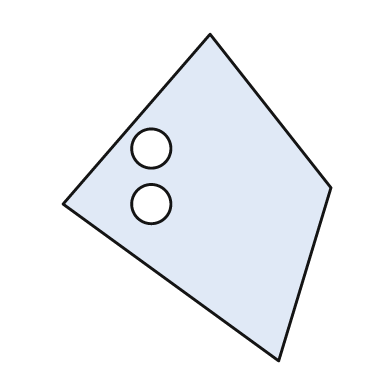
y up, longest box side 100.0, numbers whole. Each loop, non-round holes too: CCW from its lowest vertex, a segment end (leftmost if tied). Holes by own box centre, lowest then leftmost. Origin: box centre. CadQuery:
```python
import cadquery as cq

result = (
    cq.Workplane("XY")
    .moveTo(25.0, -50.0)
    .lineTo(41.0, 3.0)
    .lineTo(4.0, 50.0)
    .lineTo(-41.0, -2.0)
    .close()
    .moveTo(-14.0, -2.0)
    .circle(6.0)
    .moveTo(-14.0, 15.0)
    .circle(6.0)
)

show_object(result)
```